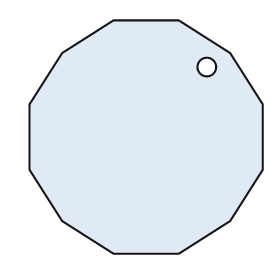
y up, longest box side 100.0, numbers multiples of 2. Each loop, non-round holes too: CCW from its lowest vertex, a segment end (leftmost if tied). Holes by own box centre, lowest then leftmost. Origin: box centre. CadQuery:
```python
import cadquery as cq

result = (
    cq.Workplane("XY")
    .moveTo(-14.0, -50.0)
    .lineTo(14.0, -50.0)
    .lineTo(36.0, -36.0)
    .lineTo(50.0, -14.0)
    .lineTo(50.0, 14.0)
    .lineTo(36.0, 36.0)
    .lineTo(14.0, 50.0)
    .lineTo(-14.0, 50.0)
    .lineTo(-36.0, 36.0)
    .lineTo(-50.0, 14.0)
    .lineTo(-50.0, -14.0)
    .lineTo(-36.0, -36.0)
    .close()
    .moveTo(26.0, 30.0)
    .circle(4.0)
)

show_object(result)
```